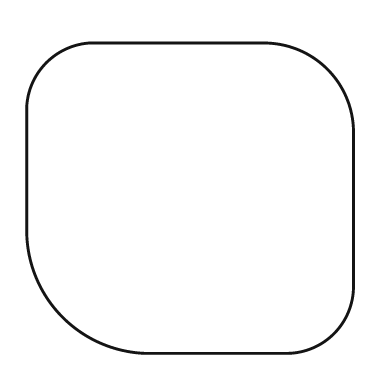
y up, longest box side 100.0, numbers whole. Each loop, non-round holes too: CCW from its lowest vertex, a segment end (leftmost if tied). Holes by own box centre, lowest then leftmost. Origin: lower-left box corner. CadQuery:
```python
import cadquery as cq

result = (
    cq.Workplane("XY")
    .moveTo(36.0, 0.0)
    .lineTo(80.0, 0.0)
    .threePointArc((94.0, 6.0), (100.0, 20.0))
    .lineTo(100.0, 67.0)
    .threePointArc((92.0, 87.0), (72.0, 95.0))
    .lineTo(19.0, 95.0)
    .threePointArc((6.0, 89.0), (0.0, 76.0))
    .lineTo(0.0, 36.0)
    .threePointArc((11.0, 11.0), (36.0, 0.0))
    .close()
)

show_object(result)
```